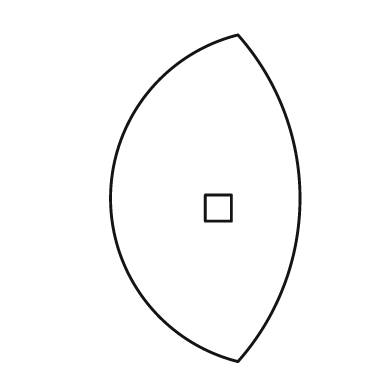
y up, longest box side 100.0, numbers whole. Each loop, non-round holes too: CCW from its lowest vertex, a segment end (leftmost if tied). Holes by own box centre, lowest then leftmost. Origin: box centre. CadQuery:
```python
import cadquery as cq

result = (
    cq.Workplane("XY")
    .moveTo(10.0, -50.0)
    .threePointArc((29.0, 0.0), (10.0, 50.0))
    .threePointArc((-29.0, 0.0), (10.0, -50.0))
    .close()
    .moveTo(0.0, -7.0)
    .lineTo(8.0, -7.0)
    .lineTo(8.0, 1.0)
    .lineTo(0.0, 1.0)
    .close()
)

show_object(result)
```